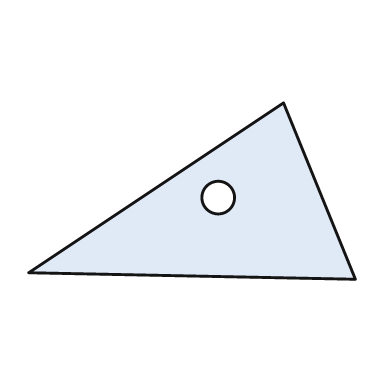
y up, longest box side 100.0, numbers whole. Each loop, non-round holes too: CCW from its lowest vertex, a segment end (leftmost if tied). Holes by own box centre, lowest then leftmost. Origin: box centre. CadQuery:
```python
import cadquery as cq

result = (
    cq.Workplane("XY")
    .moveTo(50.0, -27.0)
    .lineTo(28.0, 27.0)
    .lineTo(-50.0, -25.0)
    .close()
    .moveTo(8.0, -2.0)
    .circle(5.0)
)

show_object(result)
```